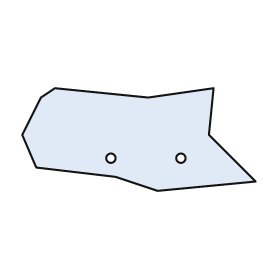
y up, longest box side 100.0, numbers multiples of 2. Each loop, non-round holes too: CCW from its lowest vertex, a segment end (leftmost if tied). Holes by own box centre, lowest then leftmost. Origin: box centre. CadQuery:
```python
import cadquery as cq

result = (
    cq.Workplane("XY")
    .moveTo(8.0, -22.0)
    .lineTo(50.0, -18.0)
    .lineTo(30.0, 2.0)
    .lineTo(32.0, 22.0)
    .lineTo(4.0, 18.0)
    .lineTo(-36.0, 22.0)
    .lineTo(-42.0, 18.0)
    .lineTo(-50.0, 2.0)
    .lineTo(-44.0, -12.0)
    .lineTo(-10.0, -16.0)
    .close()
    .moveTo(-12.0, -8.0)
    .circle(2.0)
    .moveTo(18.0, -8.0)
    .circle(2.0)
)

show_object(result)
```